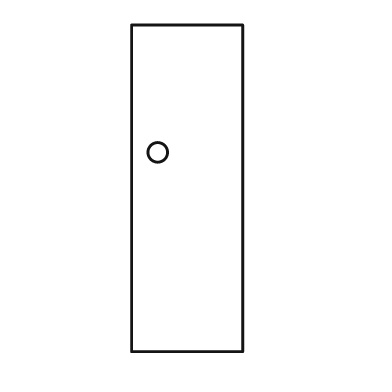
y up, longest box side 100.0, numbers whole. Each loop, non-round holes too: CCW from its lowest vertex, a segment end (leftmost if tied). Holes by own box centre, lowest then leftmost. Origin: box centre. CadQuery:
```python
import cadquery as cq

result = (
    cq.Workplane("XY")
    .moveTo(-17.0, -50.0)
    .lineTo(17.0, -50.0)
    .lineTo(17.0, 50.0)
    .lineTo(-17.0, 50.0)
    .close()
    .moveTo(-9.0, 11.0)
    .circle(3.0)
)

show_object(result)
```